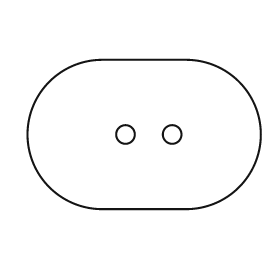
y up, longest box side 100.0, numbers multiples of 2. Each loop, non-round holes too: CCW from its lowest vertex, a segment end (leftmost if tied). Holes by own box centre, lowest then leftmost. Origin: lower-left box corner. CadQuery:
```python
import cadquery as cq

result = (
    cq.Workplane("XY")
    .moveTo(32.0, 0.0)
    .lineTo(68.0, 0.0)
    .threePointArc((100.0, 32.0), (68.0, 64.0))
    .lineTo(32.0, 64.0)
    .threePointArc((0.0, 32.0), (32.0, 0.0))
    .close()
    .moveTo(42.0, 32.0)
    .circle(4.0)
    .moveTo(62.0, 32.0)
    .circle(4.0)
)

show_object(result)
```